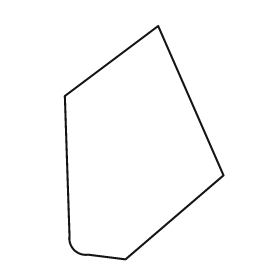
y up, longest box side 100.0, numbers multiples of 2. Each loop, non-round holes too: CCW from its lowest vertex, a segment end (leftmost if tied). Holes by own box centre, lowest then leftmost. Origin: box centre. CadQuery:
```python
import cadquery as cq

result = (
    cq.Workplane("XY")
    .moveTo(-8.0, -50.0)
    .lineTo(34.0, -14.0)
    .lineTo(6.0, 50.0)
    .lineTo(-34.0, 20.0)
    .lineTo(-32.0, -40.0)
    .threePointArc((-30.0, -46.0), (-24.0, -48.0))
    .close()
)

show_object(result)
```